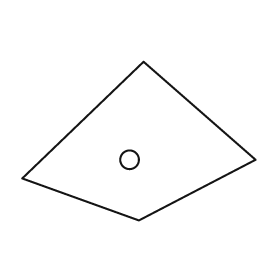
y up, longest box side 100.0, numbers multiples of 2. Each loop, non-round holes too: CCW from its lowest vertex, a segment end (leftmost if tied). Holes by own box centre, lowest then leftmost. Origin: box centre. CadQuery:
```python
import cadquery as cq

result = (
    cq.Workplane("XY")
    .moveTo(0.0, -34.0)
    .lineTo(50.0, -8.0)
    .lineTo(2.0, 34.0)
    .lineTo(-50.0, -16.0)
    .close()
    .moveTo(-4.0, -8.0)
    .circle(4.0)
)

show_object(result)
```